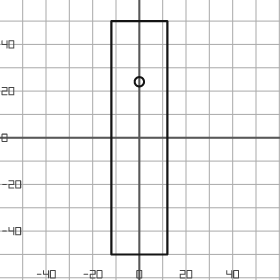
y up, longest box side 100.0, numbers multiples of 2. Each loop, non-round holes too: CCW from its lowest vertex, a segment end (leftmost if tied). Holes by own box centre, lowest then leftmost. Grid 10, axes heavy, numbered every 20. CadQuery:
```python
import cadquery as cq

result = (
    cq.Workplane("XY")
    .moveTo(-12.0, -50.0)
    .lineTo(12.0, -50.0)
    .lineTo(12.0, 50.0)
    .lineTo(-12.0, 50.0)
    .close()
    .moveTo(0.0, 24.0)
    .circle(2.0)
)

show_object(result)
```